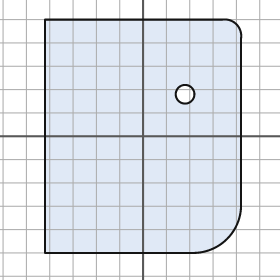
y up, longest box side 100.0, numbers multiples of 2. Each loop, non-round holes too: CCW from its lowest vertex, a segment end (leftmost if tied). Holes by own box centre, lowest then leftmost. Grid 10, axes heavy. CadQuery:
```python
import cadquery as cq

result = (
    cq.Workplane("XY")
    .moveTo(-42.0, -50.0)
    .lineTo(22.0, -50.0)
    .threePointArc((36.0, -44.0), (42.0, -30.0))
    .lineTo(42.0, 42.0)
    .threePointArc((40.0, 48.0), (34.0, 50.0))
    .lineTo(-42.0, 50.0)
    .close()
    .moveTo(18.0, 18.0)
    .circle(4.0)
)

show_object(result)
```